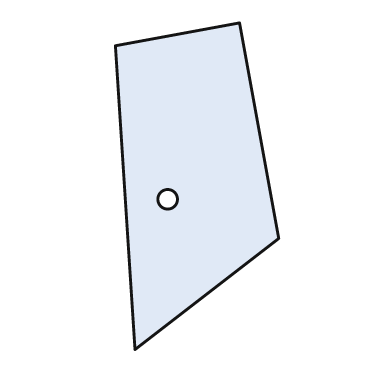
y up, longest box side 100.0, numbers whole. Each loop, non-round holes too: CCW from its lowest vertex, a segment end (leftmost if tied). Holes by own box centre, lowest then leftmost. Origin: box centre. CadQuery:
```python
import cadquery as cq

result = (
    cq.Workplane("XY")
    .moveTo(-19.0, -50.0)
    .lineTo(25.0, -16.0)
    .lineTo(13.0, 50.0)
    .lineTo(-25.0, 43.0)
    .close()
    .moveTo(-9.0, -4.0)
    .circle(3.0)
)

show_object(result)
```